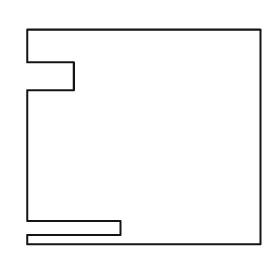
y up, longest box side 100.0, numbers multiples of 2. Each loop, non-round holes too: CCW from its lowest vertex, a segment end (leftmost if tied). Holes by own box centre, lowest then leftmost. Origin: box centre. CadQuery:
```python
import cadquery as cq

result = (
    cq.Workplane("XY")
    .moveTo(-50.0, -46.0)
    .lineTo(50.0, -46.0)
    .lineTo(50.0, 46.0)
    .lineTo(-50.0, 46.0)
    .lineTo(-50.0, 32.0)
    .lineTo(-30.0, 32.0)
    .lineTo(-30.0, 20.0)
    .lineTo(-50.0, 20.0)
    .lineTo(-50.0, -36.0)
    .lineTo(-10.0, -36.0)
    .lineTo(-10.0, -42.0)
    .lineTo(-50.0, -42.0)
    .close()
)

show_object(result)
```